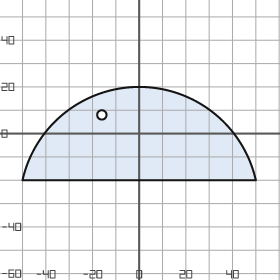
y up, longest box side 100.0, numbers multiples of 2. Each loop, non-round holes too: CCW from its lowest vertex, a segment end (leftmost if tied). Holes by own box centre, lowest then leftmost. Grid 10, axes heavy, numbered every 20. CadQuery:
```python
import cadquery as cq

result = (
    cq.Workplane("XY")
    .moveTo(-50.0, -20.0)
    .lineTo(50.0, -20.0)
    .threePointArc((0.0, 20.0), (-50.0, -20.0))
    .close()
    .moveTo(-16.0, 8.0)
    .circle(2.0)
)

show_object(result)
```